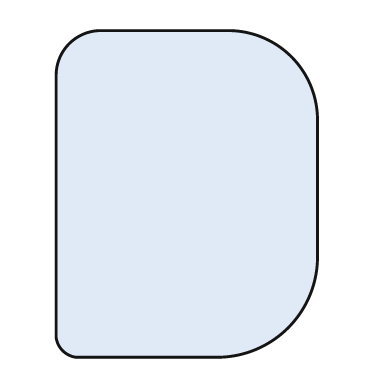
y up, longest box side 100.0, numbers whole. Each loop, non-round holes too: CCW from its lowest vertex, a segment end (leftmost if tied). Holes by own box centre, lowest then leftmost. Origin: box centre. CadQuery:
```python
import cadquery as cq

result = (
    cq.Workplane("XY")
    .moveTo(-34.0, -50.0)
    .lineTo(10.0, -50.0)
    .threePointArc((31.0, -41.0), (40.0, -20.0))
    .lineTo(40.0, 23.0)
    .threePointArc((32.0, 42.0), (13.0, 50.0))
    .lineTo(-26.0, 50.0)
    .threePointArc((-36.0, 46.0), (-40.0, 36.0))
    .lineTo(-40.0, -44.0)
    .threePointArc((-38.0, -48.0), (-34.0, -50.0))
    .close()
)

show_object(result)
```